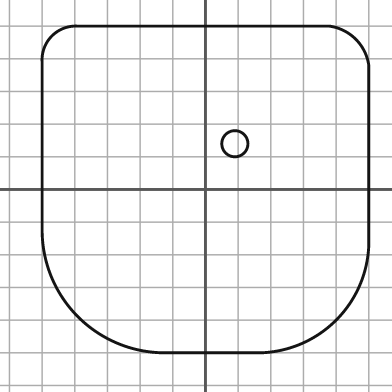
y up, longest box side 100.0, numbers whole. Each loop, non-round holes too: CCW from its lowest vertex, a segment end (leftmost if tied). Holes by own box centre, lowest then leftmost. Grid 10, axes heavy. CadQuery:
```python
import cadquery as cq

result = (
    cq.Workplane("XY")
    .moveTo(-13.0, -50.0)
    .lineTo(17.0, -50.0)
    .threePointArc((40.0, -40.0), (50.0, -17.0))
    .lineTo(50.0, 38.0)
    .threePointArc((46.0, 46.0), (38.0, 50.0))
    .lineTo(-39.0, 50.0)
    .threePointArc((-47.0, 47.0), (-50.0, 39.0))
    .lineTo(-50.0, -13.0)
    .threePointArc((-39.0, -39.0), (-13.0, -50.0))
    .close()
    .moveTo(9.0, 14.0)
    .circle(4.0)
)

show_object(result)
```